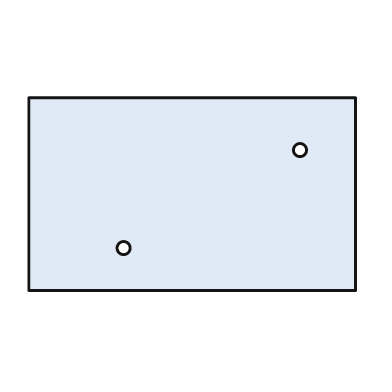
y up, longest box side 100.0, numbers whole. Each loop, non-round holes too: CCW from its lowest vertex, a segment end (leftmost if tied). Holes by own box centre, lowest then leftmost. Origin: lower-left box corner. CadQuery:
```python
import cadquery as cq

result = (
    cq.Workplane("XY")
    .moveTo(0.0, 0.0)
    .lineTo(100.0, 0.0)
    .lineTo(100.0, 59.0)
    .lineTo(0.0, 59.0)
    .close()
    .moveTo(29.0, 13.0)
    .circle(2.0)
    .moveTo(83.0, 43.0)
    .circle(2.0)
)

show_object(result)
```